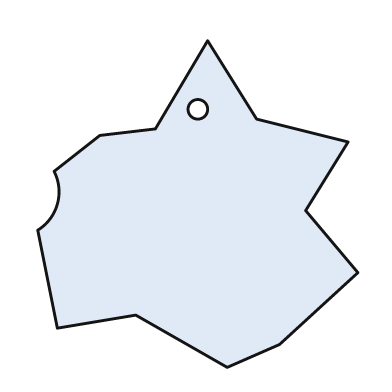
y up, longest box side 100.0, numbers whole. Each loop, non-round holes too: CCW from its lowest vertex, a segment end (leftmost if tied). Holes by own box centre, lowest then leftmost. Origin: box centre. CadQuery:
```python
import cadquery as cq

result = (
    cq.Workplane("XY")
    .moveTo(9.0, -50.0)
    .lineTo(25.0, -43.0)
    .lineTo(49.0, -21.0)
    .lineTo(33.0, -2.0)
    .lineTo(46.0, 19.0)
    .lineTo(18.0, 26.0)
    .lineTo(3.0, 50.0)
    .lineTo(-13.0, 23.0)
    .lineTo(-30.0, 21.0)
    .lineTo(-44.0, 10.0)
    .threePointArc((-43.0, 0.0), (-49.0, -8.0))
    .lineTo(-43.0, -38.0)
    .lineTo(-19.0, -34.0)
    .close()
    .moveTo(0.0, 29.0)
    .circle(3.0)
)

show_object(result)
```